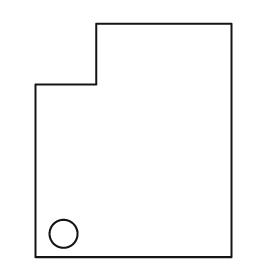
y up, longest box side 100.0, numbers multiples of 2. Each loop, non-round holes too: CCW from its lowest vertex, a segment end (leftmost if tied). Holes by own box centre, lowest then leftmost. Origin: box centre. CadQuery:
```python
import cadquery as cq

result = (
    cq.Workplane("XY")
    .moveTo(-42.0, -50.0)
    .lineTo(42.0, -50.0)
    .lineTo(42.0, 50.0)
    .lineTo(-16.0, 50.0)
    .lineTo(-16.0, 24.0)
    .lineTo(-42.0, 24.0)
    .close()
    .moveTo(-30.0, -40.0)
    .circle(6.0)
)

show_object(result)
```